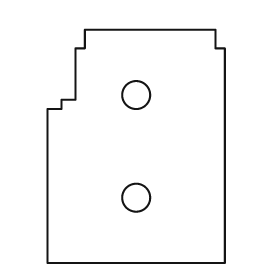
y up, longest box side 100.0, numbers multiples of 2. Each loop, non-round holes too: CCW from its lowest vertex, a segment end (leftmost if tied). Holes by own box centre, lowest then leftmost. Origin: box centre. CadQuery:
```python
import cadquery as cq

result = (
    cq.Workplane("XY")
    .moveTo(-38.0, -50.0)
    .lineTo(38.0, -50.0)
    .lineTo(38.0, 42.0)
    .lineTo(34.0, 42.0)
    .lineTo(34.0, 50.0)
    .lineTo(-22.0, 50.0)
    .lineTo(-22.0, 42.0)
    .lineTo(-26.0, 42.0)
    .lineTo(-26.0, 20.0)
    .lineTo(-32.0, 20.0)
    .lineTo(-32.0, 16.0)
    .lineTo(-38.0, 16.0)
    .close()
    .moveTo(0.0, -22.0)
    .circle(6.0)
    .moveTo(0.0, 22.0)
    .circle(6.0)
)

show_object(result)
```